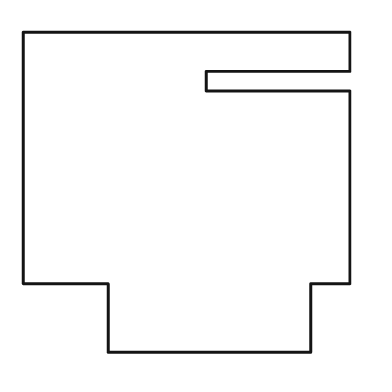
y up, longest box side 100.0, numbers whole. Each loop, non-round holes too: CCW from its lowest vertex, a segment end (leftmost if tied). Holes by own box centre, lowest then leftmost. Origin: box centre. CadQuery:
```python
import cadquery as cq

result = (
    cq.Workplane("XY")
    .moveTo(-24.0, -49.0)
    .lineTo(38.0, -49.0)
    .lineTo(38.0, -28.0)
    .lineTo(50.0, -28.0)
    .lineTo(50.0, 31.0)
    .lineTo(6.0, 31.0)
    .lineTo(6.0, 37.0)
    .lineTo(50.0, 37.0)
    .lineTo(50.0, 49.0)
    .lineTo(-50.0, 49.0)
    .lineTo(-50.0, -28.0)
    .lineTo(-24.0, -28.0)
    .close()
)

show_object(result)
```